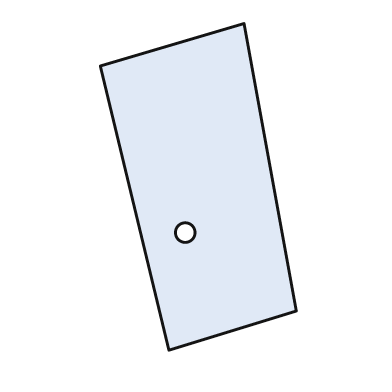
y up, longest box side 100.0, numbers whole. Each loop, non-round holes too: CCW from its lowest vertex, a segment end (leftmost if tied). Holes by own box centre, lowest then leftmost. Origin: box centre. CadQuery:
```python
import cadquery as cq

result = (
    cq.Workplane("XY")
    .moveTo(-9.0, -50.0)
    .lineTo(30.0, -38.0)
    .lineTo(14.0, 50.0)
    .lineTo(-30.0, 37.0)
    .close()
    .moveTo(-4.0, -14.0)
    .circle(3.0)
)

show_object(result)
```